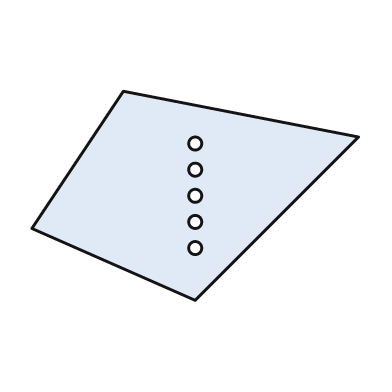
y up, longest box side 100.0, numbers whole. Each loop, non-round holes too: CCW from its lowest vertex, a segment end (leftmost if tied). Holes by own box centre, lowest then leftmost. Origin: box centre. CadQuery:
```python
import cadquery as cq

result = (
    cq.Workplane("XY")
    .moveTo(0.0, -32.0)
    .lineTo(50.0, 18.0)
    .lineTo(-22.0, 32.0)
    .lineTo(-50.0, -10.0)
    .close()
    .moveTo(0.0, -16.0)
    .circle(2.0)
    .moveTo(0.0, -8.0)
    .circle(2.0)
    .moveTo(0.0, 0.0)
    .circle(2.0)
    .moveTo(0.0, 8.0)
    .circle(2.0)
    .moveTo(0.0, 16.0)
    .circle(2.0)
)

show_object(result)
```